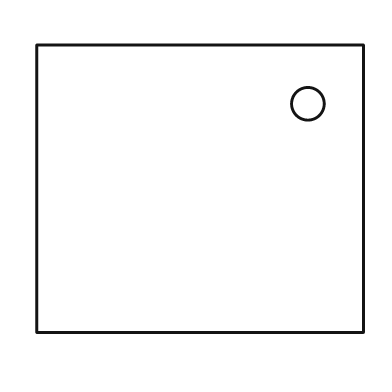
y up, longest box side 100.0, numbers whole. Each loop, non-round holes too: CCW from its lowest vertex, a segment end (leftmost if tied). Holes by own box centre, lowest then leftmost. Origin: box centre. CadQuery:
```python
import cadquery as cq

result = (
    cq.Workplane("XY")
    .moveTo(-50.0, -44.0)
    .lineTo(50.0, -44.0)
    .lineTo(50.0, 44.0)
    .lineTo(-50.0, 44.0)
    .close()
    .moveTo(33.0, 26.0)
    .circle(5.0)
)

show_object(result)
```